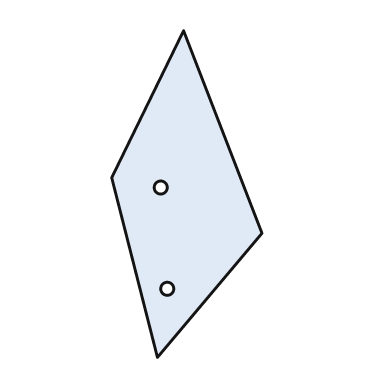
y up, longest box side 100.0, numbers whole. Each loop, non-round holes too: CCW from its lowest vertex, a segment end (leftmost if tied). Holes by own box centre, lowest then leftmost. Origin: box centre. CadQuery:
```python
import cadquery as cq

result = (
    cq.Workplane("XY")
    .moveTo(-9.0, -50.0)
    .lineTo(23.0, -12.0)
    .lineTo(-1.0, 50.0)
    .lineTo(-23.0, 5.0)
    .close()
    .moveTo(-6.0, -29.0)
    .circle(2.0)
    .moveTo(-8.0, 2.0)
    .circle(2.0)
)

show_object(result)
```